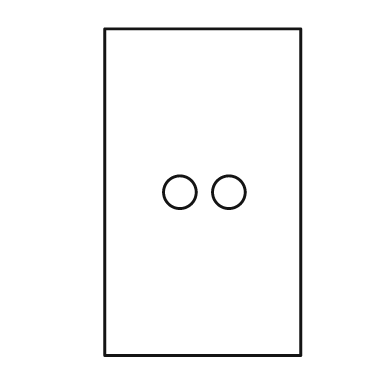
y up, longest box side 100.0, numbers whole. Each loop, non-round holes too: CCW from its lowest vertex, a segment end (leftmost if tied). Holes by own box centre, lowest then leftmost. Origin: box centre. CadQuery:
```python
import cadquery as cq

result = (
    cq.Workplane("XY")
    .moveTo(-30.0, -50.0)
    .lineTo(30.0, -50.0)
    .lineTo(30.0, 50.0)
    .lineTo(-30.0, 50.0)
    .close()
    .moveTo(-7.0, 0.0)
    .circle(5.0)
    .moveTo(8.0, 0.0)
    .circle(5.0)
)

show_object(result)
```